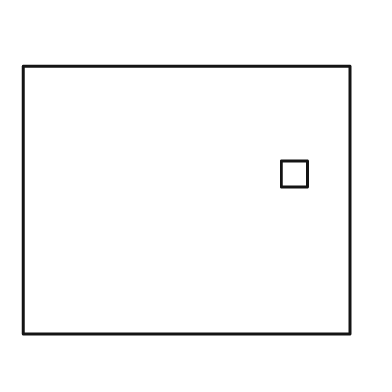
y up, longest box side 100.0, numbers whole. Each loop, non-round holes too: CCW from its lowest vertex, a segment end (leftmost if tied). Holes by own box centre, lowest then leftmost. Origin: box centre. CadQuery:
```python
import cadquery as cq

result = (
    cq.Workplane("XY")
    .moveTo(-50.0, -41.0)
    .lineTo(50.0, -41.0)
    .lineTo(50.0, 41.0)
    .lineTo(-50.0, 41.0)
    .close()
    .moveTo(29.0, 4.0)
    .lineTo(37.0, 4.0)
    .lineTo(37.0, 12.0)
    .lineTo(29.0, 12.0)
    .close()
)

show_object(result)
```